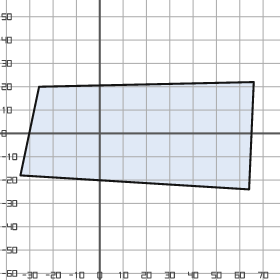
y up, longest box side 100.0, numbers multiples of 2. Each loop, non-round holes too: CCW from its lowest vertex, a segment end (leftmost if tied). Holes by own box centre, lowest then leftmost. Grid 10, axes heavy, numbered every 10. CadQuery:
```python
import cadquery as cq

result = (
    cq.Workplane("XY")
    .moveTo(64.0, -24.0)
    .lineTo(66.0, 22.0)
    .lineTo(-26.0, 20.0)
    .lineTo(-34.0, -18.0)
    .close()
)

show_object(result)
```